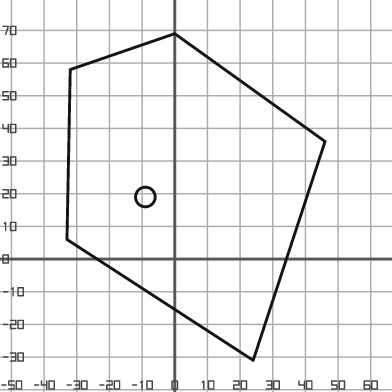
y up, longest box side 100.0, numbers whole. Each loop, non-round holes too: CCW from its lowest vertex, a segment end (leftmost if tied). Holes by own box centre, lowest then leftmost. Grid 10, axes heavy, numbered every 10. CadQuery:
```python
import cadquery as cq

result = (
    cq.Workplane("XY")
    .moveTo(24.0, -31.0)
    .lineTo(46.0, 36.0)
    .lineTo(0.0, 69.0)
    .lineTo(-32.0, 58.0)
    .lineTo(-33.0, 6.0)
    .close()
    .moveTo(-9.0, 19.0)
    .circle(3.0)
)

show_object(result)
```